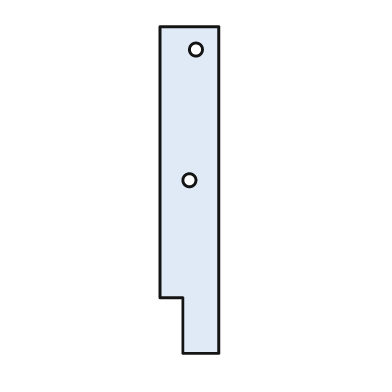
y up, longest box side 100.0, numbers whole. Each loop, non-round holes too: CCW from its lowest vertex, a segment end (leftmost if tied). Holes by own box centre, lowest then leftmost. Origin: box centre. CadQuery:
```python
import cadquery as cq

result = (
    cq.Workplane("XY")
    .moveTo(-2.0, -50.0)
    .lineTo(9.0, -50.0)
    .lineTo(9.0, 50.0)
    .lineTo(-9.0, 50.0)
    .lineTo(-9.0, -33.0)
    .lineTo(-2.0, -33.0)
    .close()
    .moveTo(0.0, 3.0)
    .circle(2.0)
    .moveTo(2.0, 43.0)
    .circle(2.0)
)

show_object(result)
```